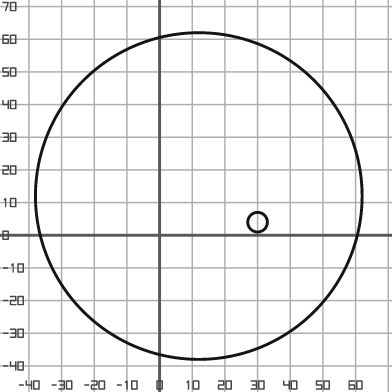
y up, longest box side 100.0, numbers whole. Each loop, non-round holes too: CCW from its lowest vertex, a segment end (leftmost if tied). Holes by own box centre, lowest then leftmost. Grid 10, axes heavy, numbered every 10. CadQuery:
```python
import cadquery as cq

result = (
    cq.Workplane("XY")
    .moveTo(12.0, 12.0)
    .circle(50.0)
    .moveTo(30.0, 4.0)
    .circle(3.0)
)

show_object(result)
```